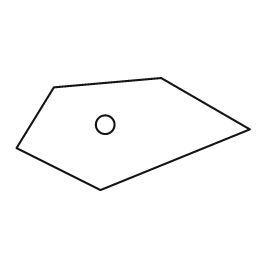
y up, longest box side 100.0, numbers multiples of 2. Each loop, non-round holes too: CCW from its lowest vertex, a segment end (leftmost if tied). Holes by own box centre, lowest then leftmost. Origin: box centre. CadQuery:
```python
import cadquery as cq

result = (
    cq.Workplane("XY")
    .moveTo(-14.0, -24.0)
    .lineTo(50.0, 2.0)
    .lineTo(12.0, 24.0)
    .lineTo(-34.0, 20.0)
    .lineTo(-50.0, -6.0)
    .close()
    .moveTo(-12.0, 4.0)
    .circle(4.0)
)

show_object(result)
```